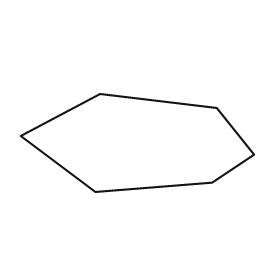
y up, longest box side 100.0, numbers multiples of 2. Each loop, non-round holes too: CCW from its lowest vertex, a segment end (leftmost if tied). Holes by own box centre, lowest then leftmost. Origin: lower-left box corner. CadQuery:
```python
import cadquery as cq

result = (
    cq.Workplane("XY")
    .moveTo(32.0, 0.0)
    .lineTo(82.0, 4.0)
    .lineTo(100.0, 16.0)
    .lineTo(84.0, 36.0)
    .lineTo(34.0, 42.0)
    .lineTo(0.0, 24.0)
    .close()
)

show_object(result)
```